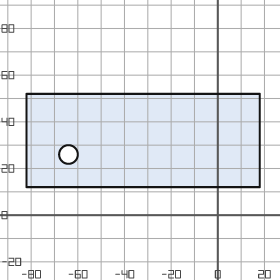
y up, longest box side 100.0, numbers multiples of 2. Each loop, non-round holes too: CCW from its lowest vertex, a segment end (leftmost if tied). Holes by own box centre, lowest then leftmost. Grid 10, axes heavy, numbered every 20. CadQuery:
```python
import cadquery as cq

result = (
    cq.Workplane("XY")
    .moveTo(-82.0, 12.0)
    .lineTo(18.0, 12.0)
    .lineTo(18.0, 52.0)
    .lineTo(-82.0, 52.0)
    .close()
    .moveTo(-64.0, 26.0)
    .circle(4.0)
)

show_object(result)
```